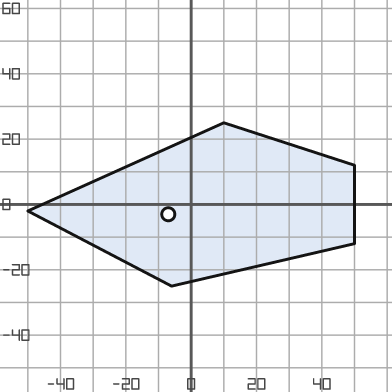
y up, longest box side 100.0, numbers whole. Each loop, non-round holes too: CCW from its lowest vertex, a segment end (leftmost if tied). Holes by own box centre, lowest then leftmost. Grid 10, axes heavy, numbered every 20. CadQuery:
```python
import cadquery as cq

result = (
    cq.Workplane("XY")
    .moveTo(-6.0, -25.0)
    .lineTo(50.0, -12.0)
    .lineTo(50.0, 12.0)
    .lineTo(10.0, 25.0)
    .lineTo(-50.0, -2.0)
    .close()
    .moveTo(-7.0, -3.0)
    .circle(2.0)
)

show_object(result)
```